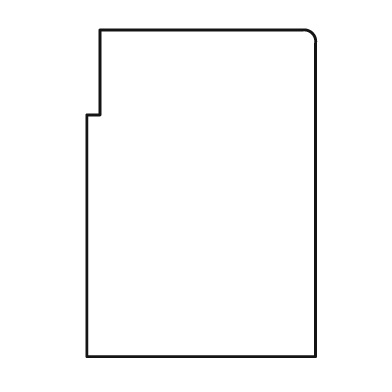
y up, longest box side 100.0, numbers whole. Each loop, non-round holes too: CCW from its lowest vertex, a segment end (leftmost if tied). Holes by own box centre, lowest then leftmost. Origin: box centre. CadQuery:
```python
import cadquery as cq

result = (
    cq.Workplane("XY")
    .moveTo(-35.0, -50.0)
    .lineTo(35.0, -50.0)
    .lineTo(35.0, 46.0)
    .threePointArc((34.0, 49.0), (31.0, 50.0))
    .lineTo(-31.0, 50.0)
    .lineTo(-31.0, 24.0)
    .lineTo(-35.0, 24.0)
    .close()
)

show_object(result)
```